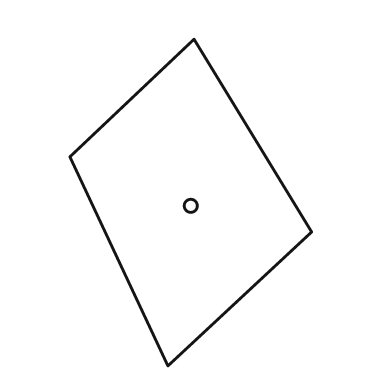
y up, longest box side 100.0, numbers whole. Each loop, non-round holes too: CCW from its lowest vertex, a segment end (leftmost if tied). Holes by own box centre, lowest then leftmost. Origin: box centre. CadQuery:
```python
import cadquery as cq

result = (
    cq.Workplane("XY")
    .moveTo(-7.0, -50.0)
    .lineTo(37.0, -9.0)
    .lineTo(1.0, 50.0)
    .lineTo(-37.0, 14.0)
    .close()
    .moveTo(0.0, -1.0)
    .circle(2.0)
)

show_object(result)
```